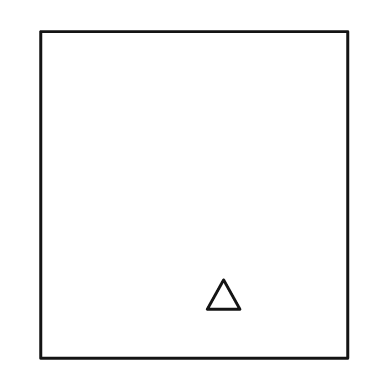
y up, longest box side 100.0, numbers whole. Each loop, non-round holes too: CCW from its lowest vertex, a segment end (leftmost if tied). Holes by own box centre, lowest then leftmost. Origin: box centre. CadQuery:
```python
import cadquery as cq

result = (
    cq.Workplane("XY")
    .moveTo(-47.0, -50.0)
    .lineTo(47.0, -50.0)
    .lineTo(47.0, 50.0)
    .lineTo(-47.0, 50.0)
    .close()
    .moveTo(4.0, -35.0)
    .lineTo(14.0, -35.0)
    .lineTo(9.0, -26.0)
    .close()
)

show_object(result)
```